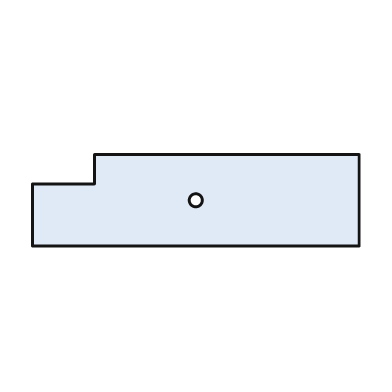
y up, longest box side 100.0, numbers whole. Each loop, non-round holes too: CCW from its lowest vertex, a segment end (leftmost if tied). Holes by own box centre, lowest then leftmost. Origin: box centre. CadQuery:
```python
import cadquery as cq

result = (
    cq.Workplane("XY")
    .moveTo(-50.0, -14.0)
    .lineTo(50.0, -14.0)
    .lineTo(50.0, 14.0)
    .lineTo(-31.0, 14.0)
    .lineTo(-31.0, 5.0)
    .lineTo(-50.0, 5.0)
    .close()
    .moveTo(0.0, 0.0)
    .circle(2.0)
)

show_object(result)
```